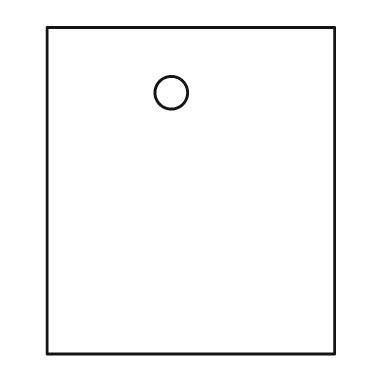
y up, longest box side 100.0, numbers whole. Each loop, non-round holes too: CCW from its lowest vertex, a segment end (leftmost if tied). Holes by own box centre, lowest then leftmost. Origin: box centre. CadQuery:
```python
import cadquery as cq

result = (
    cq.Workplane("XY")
    .moveTo(-44.0, -50.0)
    .lineTo(44.0, -50.0)
    .lineTo(44.0, 50.0)
    .lineTo(-44.0, 50.0)
    .close()
    .moveTo(-6.0, 30.0)
    .circle(5.0)
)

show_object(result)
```